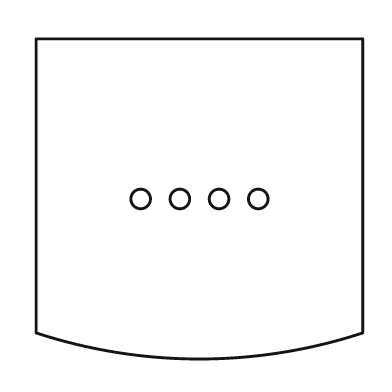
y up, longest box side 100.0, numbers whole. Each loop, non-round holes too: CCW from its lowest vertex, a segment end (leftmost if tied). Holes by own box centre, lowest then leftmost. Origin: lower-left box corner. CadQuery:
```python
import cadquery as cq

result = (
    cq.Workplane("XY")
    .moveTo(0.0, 8.0)
    .threePointArc((50.0, 0.0), (100.0, 8.0))
    .lineTo(100.0, 98.0)
    .lineTo(0.0, 98.0)
    .close()
    .moveTo(32.0, 49.0)
    .circle(3.0)
    .moveTo(44.0, 49.0)
    .circle(3.0)
    .moveTo(56.0, 49.0)
    .circle(3.0)
    .moveTo(68.0, 49.0)
    .circle(3.0)
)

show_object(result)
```